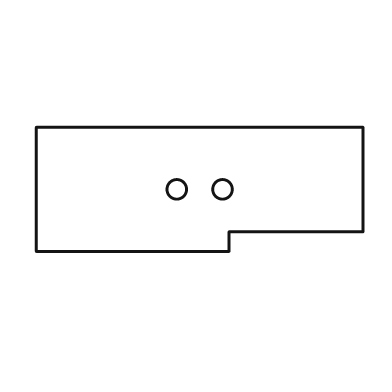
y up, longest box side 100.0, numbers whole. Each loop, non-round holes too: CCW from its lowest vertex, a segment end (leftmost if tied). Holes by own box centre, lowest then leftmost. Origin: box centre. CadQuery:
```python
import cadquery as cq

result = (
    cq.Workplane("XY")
    .moveTo(-50.0, -19.0)
    .lineTo(9.0, -19.0)
    .lineTo(9.0, -13.0)
    .lineTo(50.0, -13.0)
    .lineTo(50.0, 19.0)
    .lineTo(-50.0, 19.0)
    .close()
    .moveTo(-7.0, 0.0)
    .circle(3.0)
    .moveTo(7.0, 0.0)
    .circle(3.0)
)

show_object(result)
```